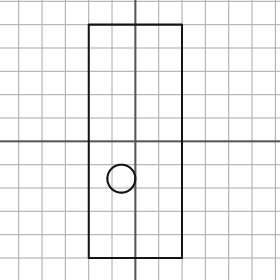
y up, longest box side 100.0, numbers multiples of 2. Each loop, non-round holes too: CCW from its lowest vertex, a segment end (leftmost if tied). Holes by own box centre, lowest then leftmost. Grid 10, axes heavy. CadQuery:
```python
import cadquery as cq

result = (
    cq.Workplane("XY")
    .moveTo(-20.0, -50.0)
    .lineTo(20.0, -50.0)
    .lineTo(20.0, 50.0)
    .lineTo(-20.0, 50.0)
    .close()
    .moveTo(-6.0, -16.0)
    .circle(6.0)
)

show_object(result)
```